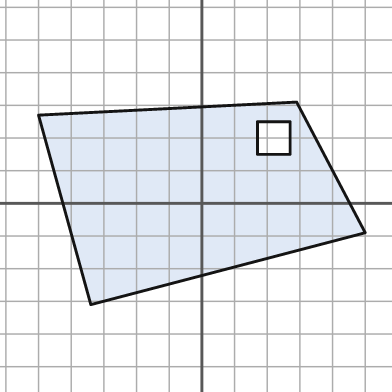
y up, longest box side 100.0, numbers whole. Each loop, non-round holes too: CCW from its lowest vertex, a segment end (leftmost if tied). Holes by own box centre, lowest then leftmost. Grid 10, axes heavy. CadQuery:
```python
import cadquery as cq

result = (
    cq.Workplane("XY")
    .moveTo(-34.0, -31.0)
    .lineTo(50.0, -9.0)
    .lineTo(29.0, 31.0)
    .lineTo(-50.0, 27.0)
    .close()
    .moveTo(17.0, 15.0)
    .lineTo(27.0, 15.0)
    .lineTo(27.0, 25.0)
    .lineTo(17.0, 25.0)
    .close()
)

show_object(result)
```